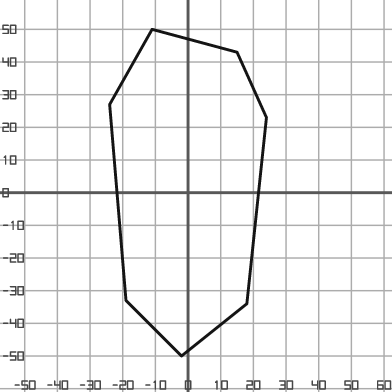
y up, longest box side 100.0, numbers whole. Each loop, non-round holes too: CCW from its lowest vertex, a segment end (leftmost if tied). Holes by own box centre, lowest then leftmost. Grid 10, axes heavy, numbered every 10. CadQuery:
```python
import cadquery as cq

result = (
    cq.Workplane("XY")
    .moveTo(-2.0, -50.0)
    .lineTo(18.0, -34.0)
    .lineTo(24.0, 23.0)
    .lineTo(15.0, 43.0)
    .lineTo(-11.0, 50.0)
    .lineTo(-24.0, 27.0)
    .lineTo(-19.0, -33.0)
    .close()
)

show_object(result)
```